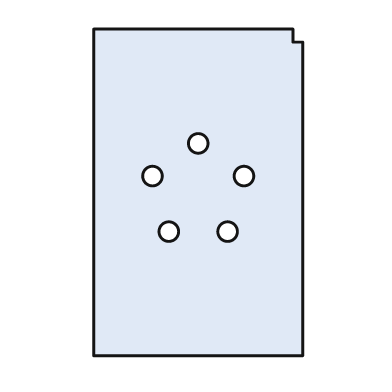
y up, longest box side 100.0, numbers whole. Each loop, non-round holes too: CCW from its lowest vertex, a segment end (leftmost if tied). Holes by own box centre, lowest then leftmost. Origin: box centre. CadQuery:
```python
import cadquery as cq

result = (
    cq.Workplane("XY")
    .moveTo(-32.0, -50.0)
    .lineTo(32.0, -50.0)
    .lineTo(32.0, 46.0)
    .lineTo(29.0, 46.0)
    .lineTo(29.0, 50.0)
    .lineTo(-32.0, 50.0)
    .close()
    .moveTo(-9.0, -12.0)
    .circle(3.0)
    .moveTo(9.0, -12.0)
    .circle(3.0)
    .moveTo(-14.0, 5.0)
    .circle(3.0)
    .moveTo(14.0, 5.0)
    .circle(3.0)
    .moveTo(0.0, 15.0)
    .circle(3.0)
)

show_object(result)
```